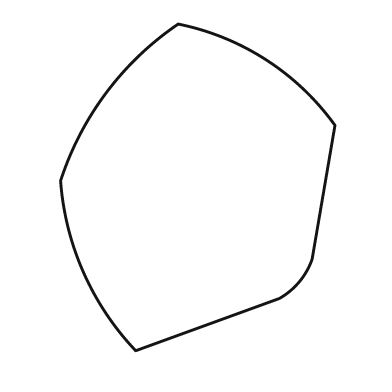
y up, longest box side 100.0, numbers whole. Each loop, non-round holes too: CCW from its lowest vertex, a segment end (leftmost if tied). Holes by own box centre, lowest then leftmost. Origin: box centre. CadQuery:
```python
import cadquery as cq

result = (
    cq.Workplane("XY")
    .moveTo(-19.0, -50.0)
    .lineTo(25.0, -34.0)
    .threePointArc((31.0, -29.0), (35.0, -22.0))
    .lineTo(42.0, 19.0)
    .threePointArc((21.0, 39.0), (-6.0, 50.0))
    .threePointArc((-28.0, 29.0), (-42.0, 2.0))
    .threePointArc((-35.0, -26.0), (-19.0, -50.0))
    .close()
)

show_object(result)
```